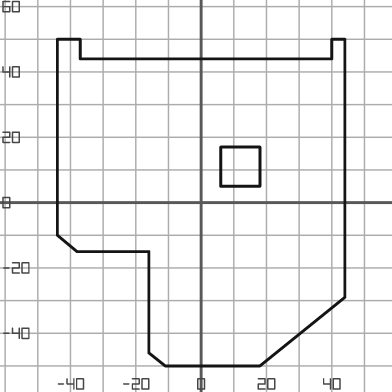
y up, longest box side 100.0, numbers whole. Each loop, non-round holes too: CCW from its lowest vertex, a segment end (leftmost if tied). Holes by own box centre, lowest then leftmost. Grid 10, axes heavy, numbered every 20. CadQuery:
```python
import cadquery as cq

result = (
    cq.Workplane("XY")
    .moveTo(-11.0, -50.0)
    .lineTo(18.0, -50.0)
    .lineTo(44.0, -29.0)
    .lineTo(44.0, 50.0)
    .lineTo(40.0, 50.0)
    .lineTo(40.0, 44.0)
    .lineTo(-37.0, 44.0)
    .lineTo(-37.0, 50.0)
    .lineTo(-44.0, 50.0)
    .lineTo(-44.0, -10.0)
    .lineTo(-38.0, -15.0)
    .lineTo(-16.0, -15.0)
    .lineTo(-16.0, -46.0)
    .close()
    .moveTo(6.0, 5.0)
    .lineTo(18.0, 5.0)
    .lineTo(18.0, 17.0)
    .lineTo(6.0, 17.0)
    .close()
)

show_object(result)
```